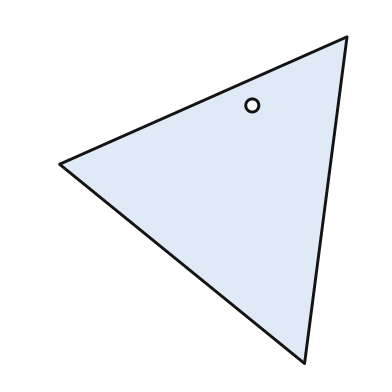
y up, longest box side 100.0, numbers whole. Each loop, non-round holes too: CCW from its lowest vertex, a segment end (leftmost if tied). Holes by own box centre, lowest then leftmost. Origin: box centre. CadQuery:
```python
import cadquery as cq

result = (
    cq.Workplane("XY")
    .moveTo(31.0, -50.0)
    .lineTo(44.0, 50.0)
    .lineTo(-44.0, 11.0)
    .close()
    .moveTo(15.0, 29.0)
    .circle(2.0)
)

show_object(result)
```